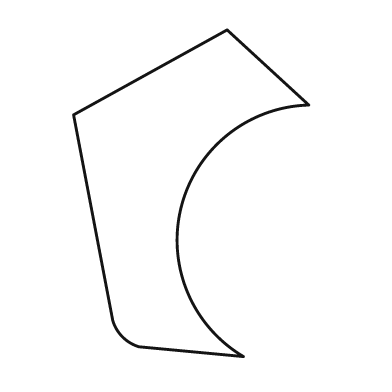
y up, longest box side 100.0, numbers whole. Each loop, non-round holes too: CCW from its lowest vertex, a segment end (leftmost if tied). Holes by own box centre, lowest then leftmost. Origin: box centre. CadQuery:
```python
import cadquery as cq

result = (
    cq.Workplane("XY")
    .moveTo(16.0, -50.0)
    .threePointArc((-3.0, -4.0), (36.0, 27.0))
    .lineTo(11.0, 50.0)
    .lineTo(-36.0, 24.0)
    .lineTo(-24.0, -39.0)
    .threePointArc((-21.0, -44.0), (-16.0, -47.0))
    .close()
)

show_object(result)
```